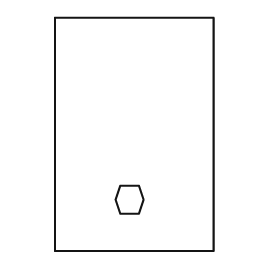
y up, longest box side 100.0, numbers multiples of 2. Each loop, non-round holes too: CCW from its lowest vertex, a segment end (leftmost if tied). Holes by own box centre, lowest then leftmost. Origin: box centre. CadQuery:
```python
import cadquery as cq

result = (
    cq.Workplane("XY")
    .moveTo(-34.0, -50.0)
    .lineTo(34.0, -50.0)
    .lineTo(34.0, 50.0)
    .lineTo(-34.0, 50.0)
    .close()
    .moveTo(-6.0, -34.0)
    .lineTo(2.0, -34.0)
    .lineTo(4.0, -28.0)
    .lineTo(2.0, -22.0)
    .lineTo(-6.0, -22.0)
    .lineTo(-8.0, -28.0)
    .close()
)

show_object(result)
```